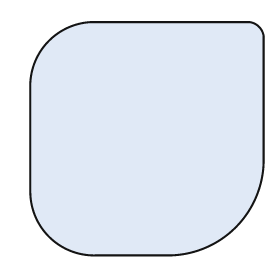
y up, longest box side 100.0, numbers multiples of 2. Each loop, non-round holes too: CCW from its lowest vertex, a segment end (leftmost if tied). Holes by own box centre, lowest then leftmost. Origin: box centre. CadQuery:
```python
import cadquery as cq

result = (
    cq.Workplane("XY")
    .moveTo(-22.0, -50.0)
    .lineTo(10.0, -50.0)
    .threePointArc((38.0, -38.0), (50.0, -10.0))
    .lineTo(50.0, 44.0)
    .threePointArc((48.0, 48.0), (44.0, 50.0))
    .lineTo(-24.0, 50.0)
    .threePointArc((-42.0, 42.0), (-50.0, 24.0))
    .lineTo(-50.0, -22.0)
    .threePointArc((-42.0, -42.0), (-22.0, -50.0))
    .close()
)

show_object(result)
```